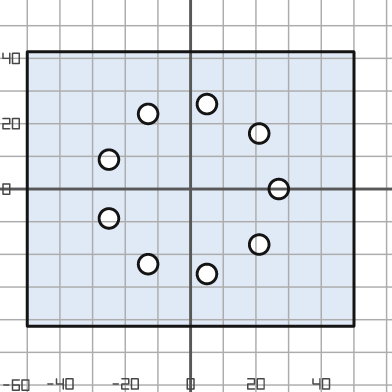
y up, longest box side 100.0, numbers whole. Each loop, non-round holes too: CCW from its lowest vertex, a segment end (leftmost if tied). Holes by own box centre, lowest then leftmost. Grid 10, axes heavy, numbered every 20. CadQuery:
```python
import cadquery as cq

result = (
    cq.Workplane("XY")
    .moveTo(-50.0, -42.0)
    .lineTo(50.0, -42.0)
    .lineTo(50.0, 42.0)
    .lineTo(-50.0, 42.0)
    .close()
    .moveTo(5.0, -26.0)
    .circle(3.0)
    .moveTo(-13.0, -23.0)
    .circle(3.0)
    .moveTo(21.0, -17.0)
    .circle(3.0)
    .moveTo(-25.0, -9.0)
    .circle(3.0)
    .moveTo(27.0, 0.0)
    .circle(3.0)
    .moveTo(-25.0, 9.0)
    .circle(3.0)
    .moveTo(21.0, 17.0)
    .circle(3.0)
    .moveTo(-13.0, 23.0)
    .circle(3.0)
    .moveTo(5.0, 26.0)
    .circle(3.0)
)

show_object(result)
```